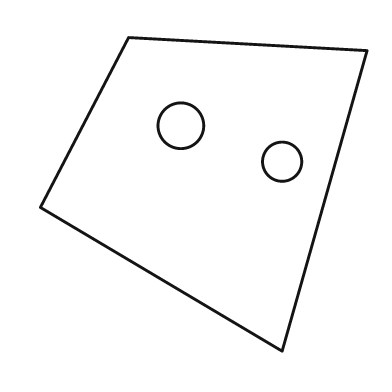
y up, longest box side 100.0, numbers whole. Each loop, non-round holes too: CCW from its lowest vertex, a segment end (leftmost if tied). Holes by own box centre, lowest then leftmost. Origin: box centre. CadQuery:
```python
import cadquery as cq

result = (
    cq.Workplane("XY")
    .moveTo(24.0, -48.0)
    .lineTo(50.0, 44.0)
    .lineTo(-23.0, 48.0)
    .lineTo(-50.0, -4.0)
    .close()
    .moveTo(24.0, 10.0)
    .circle(6.0)
    .moveTo(-7.0, 21.0)
    .circle(7.0)
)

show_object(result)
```